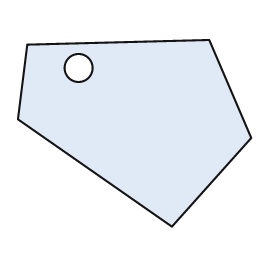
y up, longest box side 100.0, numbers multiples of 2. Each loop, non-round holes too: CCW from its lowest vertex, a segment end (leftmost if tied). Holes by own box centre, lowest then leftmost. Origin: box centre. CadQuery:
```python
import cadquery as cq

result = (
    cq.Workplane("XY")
    .moveTo(16.0, -40.0)
    .lineTo(50.0, -2.0)
    .lineTo(32.0, 40.0)
    .lineTo(-46.0, 38.0)
    .lineTo(-50.0, 6.0)
    .close()
    .moveTo(-24.0, 28.0)
    .circle(6.0)
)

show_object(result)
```